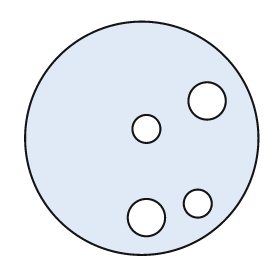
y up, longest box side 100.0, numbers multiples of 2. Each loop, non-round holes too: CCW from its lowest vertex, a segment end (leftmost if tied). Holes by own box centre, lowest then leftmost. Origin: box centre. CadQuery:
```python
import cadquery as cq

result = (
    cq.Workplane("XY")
    .moveTo(0.0, 0.0)
    .circle(50.0)
    .moveTo(2.0, -34.0)
    .circle(8.0)
    .moveTo(24.0, -28.0)
    .circle(6.0)
    .moveTo(2.0, 4.0)
    .circle(6.0)
    .moveTo(28.0, 16.0)
    .circle(8.0)
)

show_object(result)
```